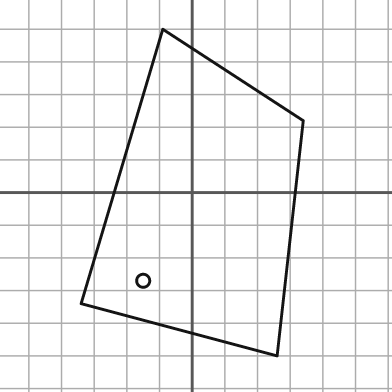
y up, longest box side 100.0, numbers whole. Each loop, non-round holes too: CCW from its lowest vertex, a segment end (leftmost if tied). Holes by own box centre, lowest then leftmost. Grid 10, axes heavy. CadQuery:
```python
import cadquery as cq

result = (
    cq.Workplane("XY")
    .moveTo(26.0, -50.0)
    .lineTo(34.0, 22.0)
    .lineTo(-9.0, 50.0)
    .lineTo(-34.0, -34.0)
    .close()
    .moveTo(-15.0, -27.0)
    .circle(2.0)
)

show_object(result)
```